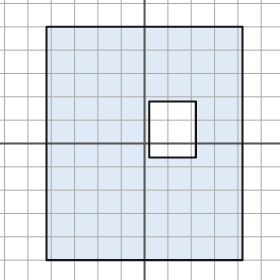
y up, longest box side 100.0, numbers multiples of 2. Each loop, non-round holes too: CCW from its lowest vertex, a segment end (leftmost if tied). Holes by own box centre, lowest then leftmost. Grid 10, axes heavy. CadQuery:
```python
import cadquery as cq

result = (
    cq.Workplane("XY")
    .moveTo(-42.0, -50.0)
    .lineTo(42.0, -50.0)
    .lineTo(42.0, 50.0)
    .lineTo(-42.0, 50.0)
    .close()
    .moveTo(2.0, -6.0)
    .lineTo(22.0, -6.0)
    .lineTo(22.0, 18.0)
    .lineTo(2.0, 18.0)
    .close()
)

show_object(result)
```